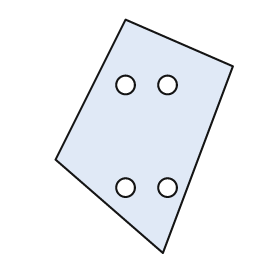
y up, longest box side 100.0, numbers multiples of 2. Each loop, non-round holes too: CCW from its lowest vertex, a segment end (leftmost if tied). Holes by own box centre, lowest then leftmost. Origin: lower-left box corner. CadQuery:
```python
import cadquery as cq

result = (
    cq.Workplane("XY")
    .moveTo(46.0, 0.0)
    .lineTo(76.0, 80.0)
    .lineTo(30.0, 100.0)
    .lineTo(0.0, 40.0)
    .close()
    .moveTo(30.0, 28.0)
    .circle(4.0)
    .moveTo(48.0, 28.0)
    .circle(4.0)
    .moveTo(30.0, 72.0)
    .circle(4.0)
    .moveTo(48.0, 72.0)
    .circle(4.0)
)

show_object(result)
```